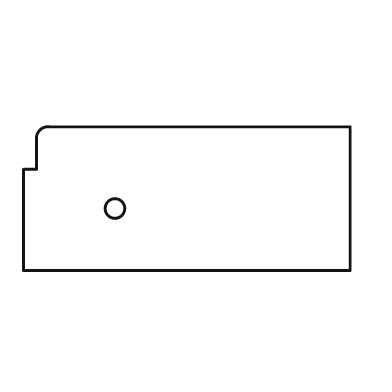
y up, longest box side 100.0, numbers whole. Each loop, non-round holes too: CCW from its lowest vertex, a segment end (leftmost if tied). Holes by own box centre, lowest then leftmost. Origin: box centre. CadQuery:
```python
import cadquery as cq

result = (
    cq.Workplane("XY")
    .moveTo(-50.0, -22.0)
    .lineTo(50.0, -22.0)
    .lineTo(50.0, 22.0)
    .lineTo(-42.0, 22.0)
    .threePointArc((-45.0, 21.0), (-46.0, 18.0))
    .lineTo(-46.0, 9.0)
    .lineTo(-50.0, 9.0)
    .close()
    .moveTo(-22.0, -3.0)
    .circle(3.0)
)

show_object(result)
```